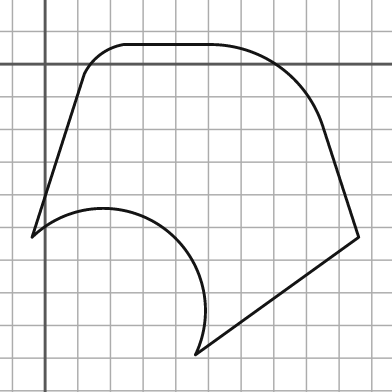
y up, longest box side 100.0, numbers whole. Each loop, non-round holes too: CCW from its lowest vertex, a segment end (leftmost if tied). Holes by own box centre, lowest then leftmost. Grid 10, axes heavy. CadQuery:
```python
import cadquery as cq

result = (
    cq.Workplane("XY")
    .moveTo(46.0, -89.0)
    .lineTo(96.0, -53.0)
    .lineTo(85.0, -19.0)
    .threePointArc((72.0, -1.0), (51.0, 6.0))
    .lineTo(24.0, 6.0)
    .threePointArc((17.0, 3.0), (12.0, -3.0))
    .lineTo(-4.0, -53.0)
    .threePointArc((36.0, -50.0), (46.0, -89.0))
    .close()
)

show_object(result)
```